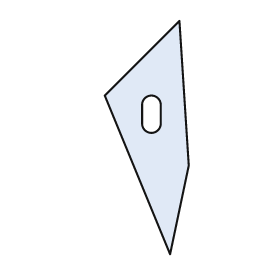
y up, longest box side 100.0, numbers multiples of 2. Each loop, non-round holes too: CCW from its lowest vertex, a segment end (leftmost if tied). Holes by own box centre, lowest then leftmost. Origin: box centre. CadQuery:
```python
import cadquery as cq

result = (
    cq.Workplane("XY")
    .moveTo(10.0, -50.0)
    .lineTo(18.0, -12.0)
    .lineTo(14.0, 50.0)
    .lineTo(-18.0, 18.0)
    .close()
    .moveTo(-2.0, 6.0)
    .threePointArc((2.0, 2.0), (6.0, 6.0))
    .lineTo(6.0, 14.0)
    .threePointArc((2.0, 18.0), (-2.0, 14.0))
    .close()
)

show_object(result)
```